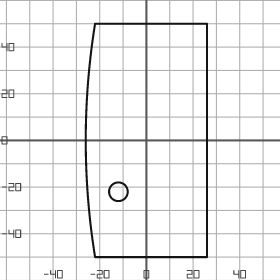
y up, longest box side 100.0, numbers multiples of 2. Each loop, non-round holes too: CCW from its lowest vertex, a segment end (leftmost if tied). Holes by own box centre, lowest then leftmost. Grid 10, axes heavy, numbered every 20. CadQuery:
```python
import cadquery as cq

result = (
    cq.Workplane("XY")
    .moveTo(-22.0, -50.0)
    .lineTo(26.0, -50.0)
    .lineTo(26.0, 50.0)
    .lineTo(-22.0, 50.0)
    .threePointArc((-26.0, 0.0), (-22.0, -50.0))
    .close()
    .moveTo(-12.0, -22.0)
    .circle(4.0)
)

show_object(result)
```